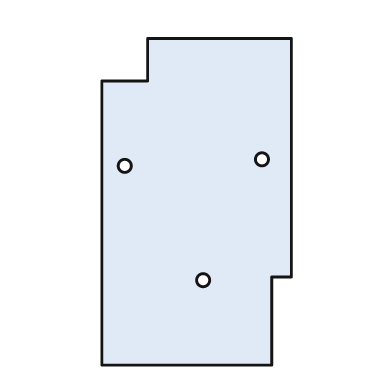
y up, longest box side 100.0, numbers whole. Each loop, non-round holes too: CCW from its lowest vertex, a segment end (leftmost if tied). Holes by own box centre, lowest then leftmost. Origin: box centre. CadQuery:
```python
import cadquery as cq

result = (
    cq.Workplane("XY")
    .moveTo(-29.0, -50.0)
    .lineTo(23.0, -50.0)
    .lineTo(23.0, -23.0)
    .lineTo(29.0, -23.0)
    .lineTo(29.0, 50.0)
    .lineTo(-15.0, 50.0)
    .lineTo(-15.0, 37.0)
    .lineTo(-29.0, 37.0)
    .close()
    .moveTo(2.0, -24.0)
    .circle(2.0)
    .moveTo(-22.0, 11.0)
    .circle(2.0)
    .moveTo(20.0, 13.0)
    .circle(2.0)
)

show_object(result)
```